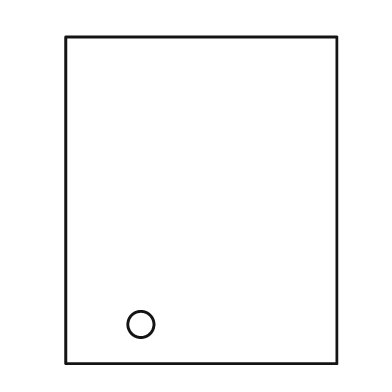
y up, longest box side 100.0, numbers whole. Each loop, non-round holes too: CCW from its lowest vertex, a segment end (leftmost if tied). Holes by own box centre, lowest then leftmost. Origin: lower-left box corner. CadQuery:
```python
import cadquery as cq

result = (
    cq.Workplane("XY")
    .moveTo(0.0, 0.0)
    .lineTo(83.0, 0.0)
    .lineTo(83.0, 100.0)
    .lineTo(0.0, 100.0)
    .close()
    .moveTo(23.0, 12.0)
    .circle(4.0)
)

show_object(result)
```